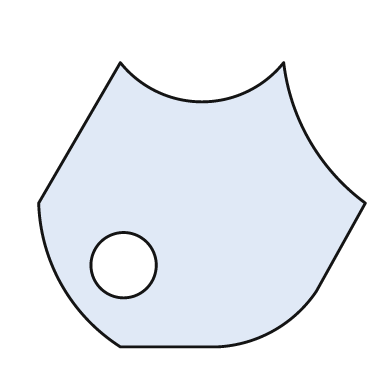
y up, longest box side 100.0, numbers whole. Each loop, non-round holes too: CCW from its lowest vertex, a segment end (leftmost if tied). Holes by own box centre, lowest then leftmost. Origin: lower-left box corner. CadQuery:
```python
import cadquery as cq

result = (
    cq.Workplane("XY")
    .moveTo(25.0, 0.0)
    .lineTo(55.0, 0.0)
    .threePointArc((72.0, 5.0), (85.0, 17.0))
    .lineTo(100.0, 44.0)
    .threePointArc((83.0, 63.0), (75.0, 87.0))
    .threePointArc((50.0, 75.0), (25.0, 87.0))
    .lineTo(0.0, 44.0)
    .threePointArc((7.0, 19.0), (25.0, 0.0))
    .close()
    .moveTo(26.0, 25.0)
    .circle(10.0)
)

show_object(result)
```